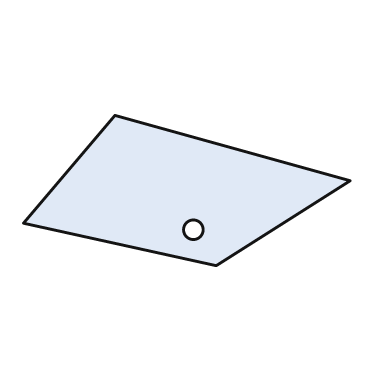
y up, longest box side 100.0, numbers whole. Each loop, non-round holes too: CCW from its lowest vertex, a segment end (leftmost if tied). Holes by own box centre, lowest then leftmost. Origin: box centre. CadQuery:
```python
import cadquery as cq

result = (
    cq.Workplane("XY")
    .moveTo(9.0, -23.0)
    .lineTo(50.0, 3.0)
    .lineTo(-22.0, 23.0)
    .lineTo(-50.0, -10.0)
    .close()
    .moveTo(2.0, -12.0)
    .circle(3.0)
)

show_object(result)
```